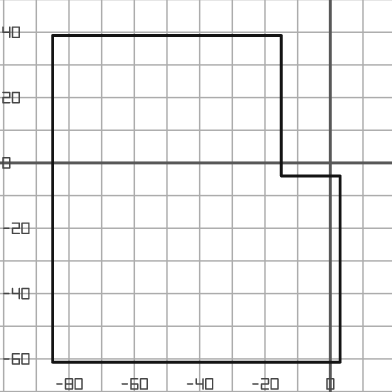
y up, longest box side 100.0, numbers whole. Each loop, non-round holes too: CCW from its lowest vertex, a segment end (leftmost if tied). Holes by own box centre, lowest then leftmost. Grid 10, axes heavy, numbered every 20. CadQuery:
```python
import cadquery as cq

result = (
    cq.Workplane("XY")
    .moveTo(-85.0, -61.0)
    .lineTo(3.0, -61.0)
    .lineTo(3.0, -4.0)
    .lineTo(-15.0, -4.0)
    .lineTo(-15.0, 39.0)
    .lineTo(-85.0, 39.0)
    .close()
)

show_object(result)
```